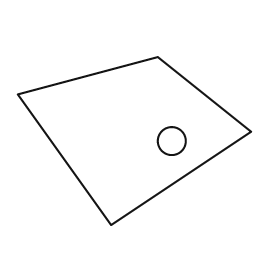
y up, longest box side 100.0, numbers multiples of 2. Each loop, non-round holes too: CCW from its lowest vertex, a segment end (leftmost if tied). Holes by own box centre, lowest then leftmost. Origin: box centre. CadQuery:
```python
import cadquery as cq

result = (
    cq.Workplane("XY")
    .moveTo(-10.0, -36.0)
    .lineTo(50.0, 4.0)
    .lineTo(10.0, 36.0)
    .lineTo(-50.0, 20.0)
    .close()
    .moveTo(16.0, 0.0)
    .circle(6.0)
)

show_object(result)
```